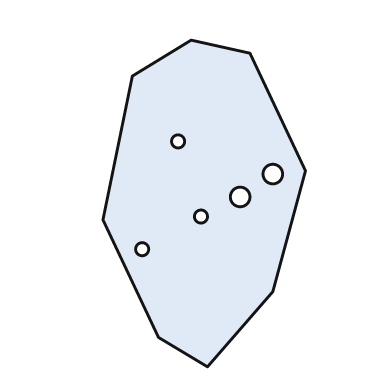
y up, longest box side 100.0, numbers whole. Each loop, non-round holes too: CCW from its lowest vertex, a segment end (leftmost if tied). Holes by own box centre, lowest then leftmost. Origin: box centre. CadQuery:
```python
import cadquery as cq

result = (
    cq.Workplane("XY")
    .moveTo(1.0, -50.0)
    .lineTo(21.0, -27.0)
    .lineTo(31.0, 10.0)
    .lineTo(14.0, 46.0)
    .lineTo(-4.0, 50.0)
    .lineTo(-22.0, 39.0)
    .lineTo(-31.0, -5.0)
    .lineTo(-14.0, -41.0)
    .close()
    .moveTo(-19.0, -14.0)
    .circle(2.0)
    .moveTo(-1.0, -4.0)
    .circle(2.0)
    .moveTo(11.0, 2.0)
    .circle(3.0)
    .moveTo(21.0, 9.0)
    .circle(3.0)
    .moveTo(-8.0, 19.0)
    .circle(2.0)
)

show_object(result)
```